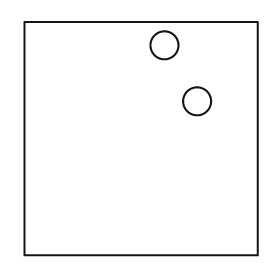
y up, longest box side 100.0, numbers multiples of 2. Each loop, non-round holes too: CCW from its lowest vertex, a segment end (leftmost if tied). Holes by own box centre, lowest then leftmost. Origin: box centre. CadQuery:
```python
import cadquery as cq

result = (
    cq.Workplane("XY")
    .moveTo(-50.0, -50.0)
    .lineTo(50.0, -50.0)
    .lineTo(50.0, 50.0)
    .lineTo(-50.0, 50.0)
    .close()
    .moveTo(24.0, 16.0)
    .circle(6.0)
    .moveTo(10.0, 40.0)
    .circle(6.0)
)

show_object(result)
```